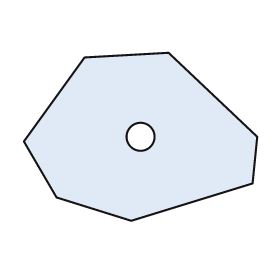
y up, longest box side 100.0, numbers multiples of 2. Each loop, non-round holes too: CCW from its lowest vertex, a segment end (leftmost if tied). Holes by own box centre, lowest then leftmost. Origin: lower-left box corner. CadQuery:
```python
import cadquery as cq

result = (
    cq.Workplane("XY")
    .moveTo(46.0, 0.0)
    .lineTo(98.0, 16.0)
    .lineTo(100.0, 36.0)
    .lineTo(62.0, 72.0)
    .lineTo(26.0, 70.0)
    .lineTo(0.0, 34.0)
    .lineTo(14.0, 10.0)
    .close()
    .moveTo(50.0, 36.0)
    .circle(6.0)
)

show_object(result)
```